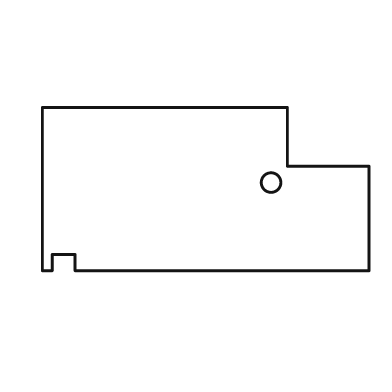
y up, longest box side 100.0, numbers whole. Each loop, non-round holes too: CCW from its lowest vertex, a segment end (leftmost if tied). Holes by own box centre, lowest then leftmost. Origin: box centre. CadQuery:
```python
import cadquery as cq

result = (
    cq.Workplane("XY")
    .moveTo(-50.0, -25.0)
    .lineTo(-47.0, -25.0)
    .lineTo(-47.0, -20.0)
    .lineTo(-40.0, -20.0)
    .lineTo(-40.0, -25.0)
    .lineTo(50.0, -25.0)
    .lineTo(50.0, 7.0)
    .lineTo(25.0, 7.0)
    .lineTo(25.0, 25.0)
    .lineTo(-50.0, 25.0)
    .close()
    .moveTo(20.0, 2.0)
    .circle(3.0)
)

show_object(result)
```